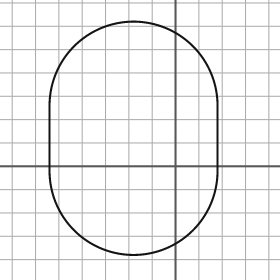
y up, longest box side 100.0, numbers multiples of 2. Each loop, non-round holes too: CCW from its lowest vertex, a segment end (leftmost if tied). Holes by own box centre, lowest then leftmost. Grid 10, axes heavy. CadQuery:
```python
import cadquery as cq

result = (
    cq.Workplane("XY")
    .moveTo(-54.0, -2.0)
    .threePointArc((-18.0, -38.0), (18.0, -2.0))
    .lineTo(18.0, 26.0)
    .threePointArc((-18.0, 62.0), (-54.0, 26.0))
    .close()
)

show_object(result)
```